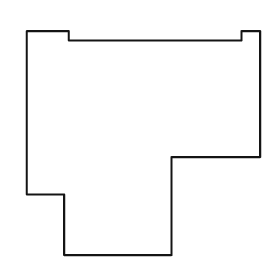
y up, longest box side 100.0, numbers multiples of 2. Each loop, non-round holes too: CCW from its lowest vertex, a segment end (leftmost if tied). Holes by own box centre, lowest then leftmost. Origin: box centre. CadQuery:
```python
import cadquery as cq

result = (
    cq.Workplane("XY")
    .moveTo(-34.0, -48.0)
    .lineTo(12.0, -48.0)
    .lineTo(12.0, -6.0)
    .lineTo(50.0, -6.0)
    .lineTo(50.0, 48.0)
    .lineTo(42.0, 48.0)
    .lineTo(42.0, 44.0)
    .lineTo(-32.0, 44.0)
    .lineTo(-32.0, 48.0)
    .lineTo(-50.0, 48.0)
    .lineTo(-50.0, -22.0)
    .lineTo(-34.0, -22.0)
    .close()
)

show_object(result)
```